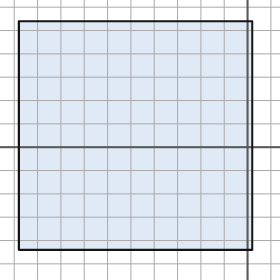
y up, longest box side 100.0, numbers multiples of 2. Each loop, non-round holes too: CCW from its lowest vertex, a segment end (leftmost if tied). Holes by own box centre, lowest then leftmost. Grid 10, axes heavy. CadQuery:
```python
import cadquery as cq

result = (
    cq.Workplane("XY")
    .moveTo(-98.0, -44.0)
    .lineTo(2.0, -44.0)
    .lineTo(2.0, 54.0)
    .lineTo(-98.0, 54.0)
    .close()
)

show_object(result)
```